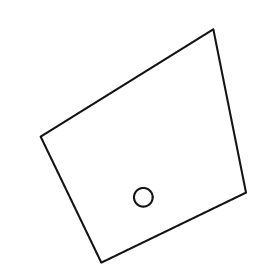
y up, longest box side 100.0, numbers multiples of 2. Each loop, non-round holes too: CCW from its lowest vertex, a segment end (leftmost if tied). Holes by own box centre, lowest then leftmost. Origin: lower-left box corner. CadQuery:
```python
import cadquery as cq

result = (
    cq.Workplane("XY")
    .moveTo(26.0, 0.0)
    .lineTo(88.0, 30.0)
    .lineTo(74.0, 100.0)
    .lineTo(0.0, 54.0)
    .close()
    .moveTo(44.0, 28.0)
    .circle(4.0)
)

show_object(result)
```